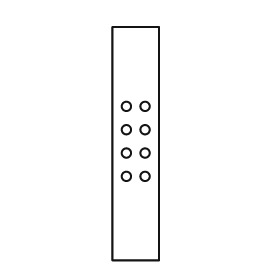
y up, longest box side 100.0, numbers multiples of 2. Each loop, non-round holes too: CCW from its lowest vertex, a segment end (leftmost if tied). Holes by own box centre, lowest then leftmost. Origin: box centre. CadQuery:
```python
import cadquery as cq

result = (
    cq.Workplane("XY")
    .moveTo(-10.0, -50.0)
    .lineTo(10.0, -50.0)
    .lineTo(10.0, 50.0)
    .lineTo(-10.0, 50.0)
    .close()
    .moveTo(-4.0, -14.0)
    .circle(2.0)
    .moveTo(4.0, -14.0)
    .circle(2.0)
    .moveTo(-4.0, -4.0)
    .circle(2.0)
    .moveTo(4.0, -4.0)
    .circle(2.0)
    .moveTo(-4.0, 6.0)
    .circle(2.0)
    .moveTo(4.0, 6.0)
    .circle(2.0)
    .moveTo(-4.0, 16.0)
    .circle(2.0)
    .moveTo(4.0, 16.0)
    .circle(2.0)
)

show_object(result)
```